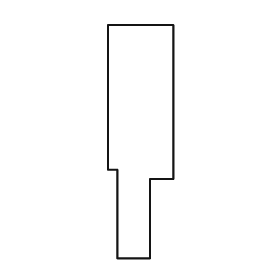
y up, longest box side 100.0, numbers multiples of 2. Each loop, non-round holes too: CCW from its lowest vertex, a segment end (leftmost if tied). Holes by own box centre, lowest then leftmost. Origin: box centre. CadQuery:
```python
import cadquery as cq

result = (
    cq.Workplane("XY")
    .moveTo(-10.0, -50.0)
    .lineTo(4.0, -50.0)
    .lineTo(4.0, -16.0)
    .lineTo(14.0, -16.0)
    .lineTo(14.0, 50.0)
    .lineTo(-14.0, 50.0)
    .lineTo(-14.0, -12.0)
    .lineTo(-10.0, -12.0)
    .close()
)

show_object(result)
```